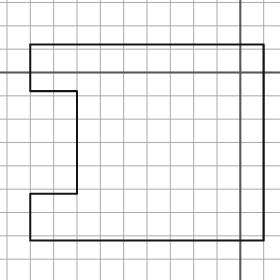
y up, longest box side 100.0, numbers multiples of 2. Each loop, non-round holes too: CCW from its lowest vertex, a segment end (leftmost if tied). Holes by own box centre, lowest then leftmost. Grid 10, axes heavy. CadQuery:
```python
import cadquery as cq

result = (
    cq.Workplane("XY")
    .moveTo(-90.0, -72.0)
    .lineTo(10.0, -72.0)
    .lineTo(10.0, 12.0)
    .lineTo(-90.0, 12.0)
    .lineTo(-90.0, -8.0)
    .lineTo(-70.0, -8.0)
    .lineTo(-70.0, -52.0)
    .lineTo(-90.0, -52.0)
    .close()
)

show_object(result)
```